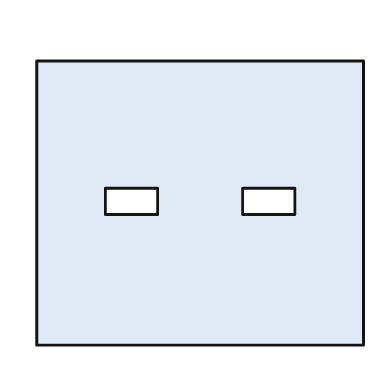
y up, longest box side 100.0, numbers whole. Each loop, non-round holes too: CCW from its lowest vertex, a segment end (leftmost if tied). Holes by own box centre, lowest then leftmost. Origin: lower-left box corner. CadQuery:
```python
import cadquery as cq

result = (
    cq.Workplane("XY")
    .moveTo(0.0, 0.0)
    .lineTo(100.0, 0.0)
    .lineTo(100.0, 87.0)
    .lineTo(0.0, 87.0)
    .close()
    .moveTo(21.0, 40.0)
    .lineTo(37.0, 40.0)
    .lineTo(37.0, 48.0)
    .lineTo(21.0, 48.0)
    .close()
    .moveTo(63.0, 40.0)
    .lineTo(79.0, 40.0)
    .lineTo(79.0, 48.0)
    .lineTo(63.0, 48.0)
    .close()
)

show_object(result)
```